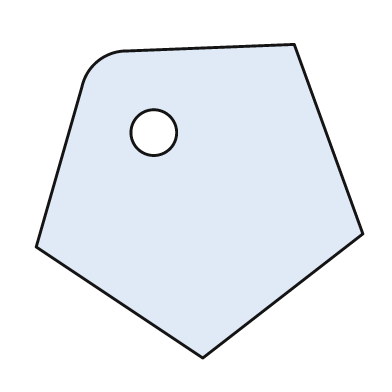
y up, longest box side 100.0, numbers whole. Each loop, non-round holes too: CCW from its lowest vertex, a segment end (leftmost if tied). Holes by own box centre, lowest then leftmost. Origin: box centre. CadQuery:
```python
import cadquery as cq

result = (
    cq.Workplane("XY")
    .moveTo(1.0, -48.0)
    .lineTo(50.0, -10.0)
    .lineTo(29.0, 48.0)
    .lineTo(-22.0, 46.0)
    .threePointArc((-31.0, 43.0), (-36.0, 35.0))
    .lineTo(-50.0, -14.0)
    .close()
    .moveTo(-14.0, 21.0)
    .circle(7.0)
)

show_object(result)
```